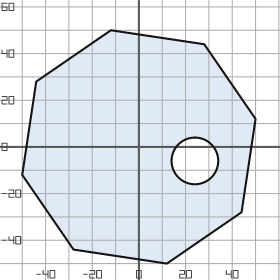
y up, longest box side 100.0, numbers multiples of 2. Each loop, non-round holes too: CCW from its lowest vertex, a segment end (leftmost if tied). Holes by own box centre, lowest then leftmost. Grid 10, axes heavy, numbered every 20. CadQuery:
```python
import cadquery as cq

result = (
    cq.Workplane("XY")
    .moveTo(12.0, -50.0)
    .lineTo(44.0, -28.0)
    .lineTo(50.0, 12.0)
    .lineTo(28.0, 44.0)
    .lineTo(-12.0, 50.0)
    .lineTo(-44.0, 28.0)
    .lineTo(-50.0, -12.0)
    .lineTo(-28.0, -44.0)
    .close()
    .moveTo(24.0, -6.0)
    .circle(10.0)
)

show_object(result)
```